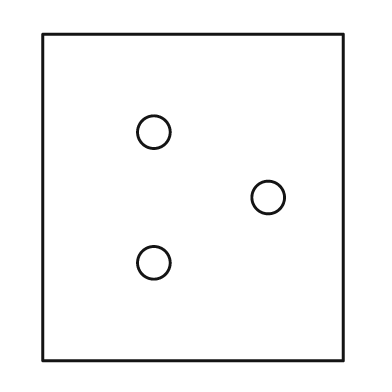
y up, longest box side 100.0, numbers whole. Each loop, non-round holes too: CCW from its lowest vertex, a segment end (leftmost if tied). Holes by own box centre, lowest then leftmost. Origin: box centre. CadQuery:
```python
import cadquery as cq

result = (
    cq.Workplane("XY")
    .moveTo(-46.0, -50.0)
    .lineTo(46.0, -50.0)
    .lineTo(46.0, 50.0)
    .lineTo(-46.0, 50.0)
    .close()
    .moveTo(-12.0, -20.0)
    .circle(5.0)
    .moveTo(23.0, 0.0)
    .circle(5.0)
    .moveTo(-12.0, 20.0)
    .circle(5.0)
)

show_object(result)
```